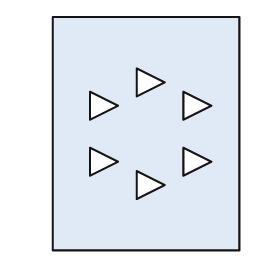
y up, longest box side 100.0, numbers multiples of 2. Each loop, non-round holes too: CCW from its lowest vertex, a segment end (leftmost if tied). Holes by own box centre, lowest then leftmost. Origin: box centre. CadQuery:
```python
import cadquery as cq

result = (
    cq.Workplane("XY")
    .moveTo(-40.0, -50.0)
    .lineTo(40.0, -50.0)
    .lineTo(40.0, 50.0)
    .lineTo(-40.0, 50.0)
    .close()
    .moveTo(-4.0, -28.0)
    .lineTo(8.0, -22.0)
    .lineTo(-4.0, -16.0)
    .close()
    .moveTo(-24.0, -18.0)
    .lineTo(-12.0, -12.0)
    .lineTo(-24.0, -6.0)
    .close()
    .moveTo(16.0, -18.0)
    .lineTo(28.0, -12.0)
    .lineTo(16.0, -6.0)
    .close()
    .moveTo(-24.0, 6.0)
    .lineTo(-12.0, 12.0)
    .lineTo(-24.0, 18.0)
    .close()
    .moveTo(16.0, 6.0)
    .lineTo(28.0, 12.0)
    .lineTo(16.0, 18.0)
    .close()
    .moveTo(-4.0, 16.0)
    .lineTo(8.0, 22.0)
    .lineTo(-4.0, 28.0)
    .close()
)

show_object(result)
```